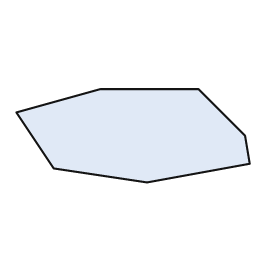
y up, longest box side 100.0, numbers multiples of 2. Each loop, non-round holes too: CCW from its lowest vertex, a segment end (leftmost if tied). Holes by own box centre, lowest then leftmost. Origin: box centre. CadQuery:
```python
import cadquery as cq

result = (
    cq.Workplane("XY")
    .moveTo(6.0, -20.0)
    .lineTo(50.0, -12.0)
    .lineTo(48.0, 0.0)
    .lineTo(28.0, 20.0)
    .lineTo(-14.0, 20.0)
    .lineTo(-50.0, 10.0)
    .lineTo(-34.0, -14.0)
    .close()
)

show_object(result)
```